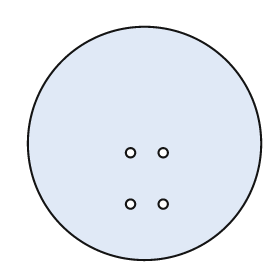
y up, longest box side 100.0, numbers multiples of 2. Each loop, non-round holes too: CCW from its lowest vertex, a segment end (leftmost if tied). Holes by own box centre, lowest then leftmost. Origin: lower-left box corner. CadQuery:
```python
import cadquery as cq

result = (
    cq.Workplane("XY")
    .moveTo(50.0, 50.0)
    .circle(50.0)
    .moveTo(44.0, 24.0)
    .circle(2.0)
    .moveTo(58.0, 24.0)
    .circle(2.0)
    .moveTo(44.0, 46.0)
    .circle(2.0)
    .moveTo(58.0, 46.0)
    .circle(2.0)
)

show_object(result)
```